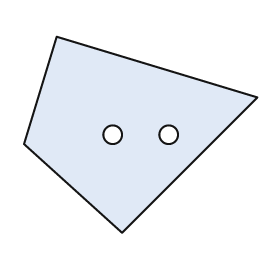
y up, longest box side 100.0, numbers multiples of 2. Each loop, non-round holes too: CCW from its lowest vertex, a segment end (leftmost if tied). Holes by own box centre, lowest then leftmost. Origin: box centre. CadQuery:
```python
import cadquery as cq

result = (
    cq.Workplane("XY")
    .moveTo(-8.0, -42.0)
    .lineTo(50.0, 16.0)
    .lineTo(-36.0, 42.0)
    .lineTo(-50.0, -4.0)
    .close()
    .moveTo(-12.0, 0.0)
    .circle(4.0)
    .moveTo(12.0, 0.0)
    .circle(4.0)
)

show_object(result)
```